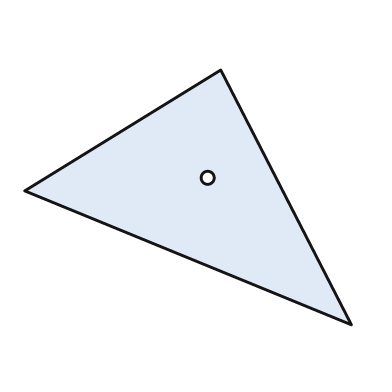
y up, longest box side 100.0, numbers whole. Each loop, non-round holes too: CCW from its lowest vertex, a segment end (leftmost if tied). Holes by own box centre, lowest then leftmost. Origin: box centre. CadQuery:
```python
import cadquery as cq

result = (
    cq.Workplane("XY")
    .moveTo(50.0, -39.0)
    .lineTo(10.0, 39.0)
    .lineTo(-50.0, 2.0)
    .close()
    .moveTo(6.0, 6.0)
    .circle(2.0)
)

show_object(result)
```